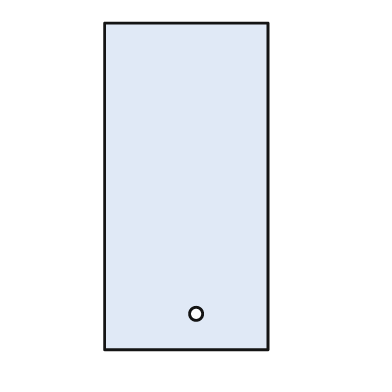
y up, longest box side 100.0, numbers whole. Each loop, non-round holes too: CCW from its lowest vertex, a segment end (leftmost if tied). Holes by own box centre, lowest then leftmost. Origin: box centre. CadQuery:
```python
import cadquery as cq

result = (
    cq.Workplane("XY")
    .moveTo(-25.0, -50.0)
    .lineTo(25.0, -50.0)
    .lineTo(25.0, 50.0)
    .lineTo(-25.0, 50.0)
    .close()
    .moveTo(3.0, -39.0)
    .circle(2.0)
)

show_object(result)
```